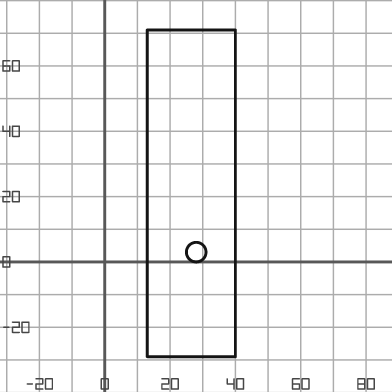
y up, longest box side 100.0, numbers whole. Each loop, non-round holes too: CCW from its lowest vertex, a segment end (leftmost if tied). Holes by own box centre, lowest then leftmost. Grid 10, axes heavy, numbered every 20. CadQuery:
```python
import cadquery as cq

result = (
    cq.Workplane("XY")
    .moveTo(13.0, -29.0)
    .lineTo(40.0, -29.0)
    .lineTo(40.0, 71.0)
    .lineTo(13.0, 71.0)
    .close()
    .moveTo(28.0, 3.0)
    .circle(3.0)
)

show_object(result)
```